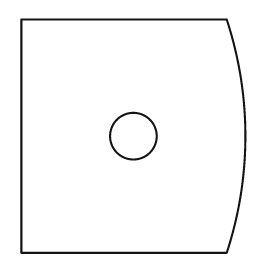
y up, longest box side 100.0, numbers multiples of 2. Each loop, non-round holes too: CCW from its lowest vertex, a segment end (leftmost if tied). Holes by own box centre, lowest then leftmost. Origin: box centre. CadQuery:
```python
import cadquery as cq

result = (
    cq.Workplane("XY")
    .moveTo(-48.0, -50.0)
    .lineTo(40.0, -50.0)
    .threePointArc((48.0, 0.0), (40.0, 50.0))
    .lineTo(-48.0, 50.0)
    .close()
    .moveTo(0.0, 0.0)
    .circle(10.0)
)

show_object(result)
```